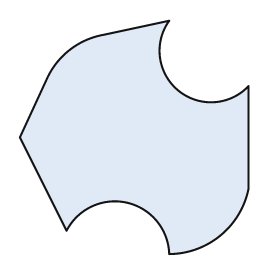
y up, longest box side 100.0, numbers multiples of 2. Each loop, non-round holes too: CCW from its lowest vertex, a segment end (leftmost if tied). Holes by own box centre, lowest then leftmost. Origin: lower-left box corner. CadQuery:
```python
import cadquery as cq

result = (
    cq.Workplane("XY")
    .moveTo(64.0, 0.0)
    .threePointArc((86.0, 8.0), (98.0, 28.0))
    .lineTo(98.0, 72.0)
    .threePointArc((68.0, 70.0), (64.0, 100.0))
    .lineTo(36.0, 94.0)
    .threePointArc((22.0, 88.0), (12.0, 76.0))
    .lineTo(0.0, 50.0)
    .lineTo(20.0, 10.0)
    .threePointArc((46.0, 22.0), (64.0, 0.0))
    .close()
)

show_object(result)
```